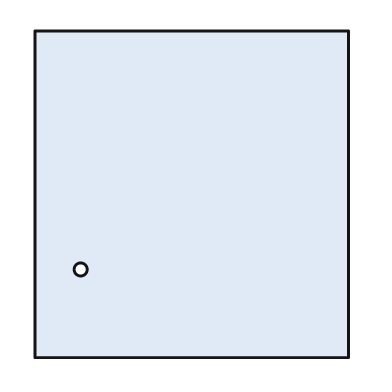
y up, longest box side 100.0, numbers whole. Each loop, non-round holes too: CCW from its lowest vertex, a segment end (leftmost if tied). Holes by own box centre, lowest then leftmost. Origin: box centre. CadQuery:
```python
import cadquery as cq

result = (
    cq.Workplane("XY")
    .moveTo(-48.0, -50.0)
    .lineTo(48.0, -50.0)
    .lineTo(48.0, 50.0)
    .lineTo(-48.0, 50.0)
    .close()
    .moveTo(-34.0, -23.0)
    .circle(2.0)
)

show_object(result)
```